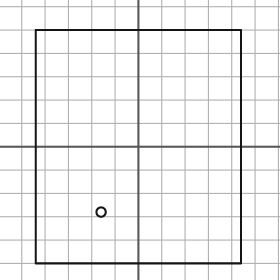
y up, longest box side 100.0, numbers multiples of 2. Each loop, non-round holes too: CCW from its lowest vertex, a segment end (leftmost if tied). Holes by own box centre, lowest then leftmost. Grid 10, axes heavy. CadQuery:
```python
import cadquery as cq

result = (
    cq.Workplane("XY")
    .moveTo(-44.0, -50.0)
    .lineTo(44.0, -50.0)
    .lineTo(44.0, 50.0)
    .lineTo(-44.0, 50.0)
    .close()
    .moveTo(-16.0, -28.0)
    .circle(2.0)
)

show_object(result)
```